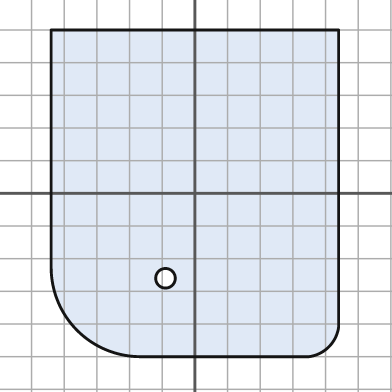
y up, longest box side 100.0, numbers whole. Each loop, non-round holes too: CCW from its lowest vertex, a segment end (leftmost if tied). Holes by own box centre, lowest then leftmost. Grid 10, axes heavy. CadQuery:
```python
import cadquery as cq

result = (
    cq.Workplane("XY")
    .moveTo(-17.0, -50.0)
    .lineTo(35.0, -50.0)
    .threePointArc((41.0, -47.0), (44.0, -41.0))
    .lineTo(44.0, 50.0)
    .lineTo(-44.0, 50.0)
    .lineTo(-44.0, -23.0)
    .threePointArc((-36.0, -42.0), (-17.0, -50.0))
    .close()
    .moveTo(-9.0, -26.0)
    .circle(3.0)
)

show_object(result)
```